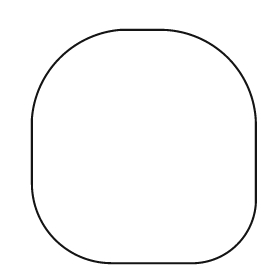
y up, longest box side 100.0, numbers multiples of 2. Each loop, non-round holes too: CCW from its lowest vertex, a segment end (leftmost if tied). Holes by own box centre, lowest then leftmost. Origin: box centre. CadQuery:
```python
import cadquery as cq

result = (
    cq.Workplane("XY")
    .moveTo(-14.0, -50.0)
    .lineTo(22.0, -50.0)
    .threePointArc((40.0, -42.0), (48.0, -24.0))
    .lineTo(48.0, 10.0)
    .threePointArc((36.0, 38.0), (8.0, 50.0))
    .lineTo(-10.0, 50.0)
    .threePointArc((-36.0, 38.0), (-48.0, 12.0))
    .lineTo(-48.0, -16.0)
    .threePointArc((-38.0, -40.0), (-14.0, -50.0))
    .close()
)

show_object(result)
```